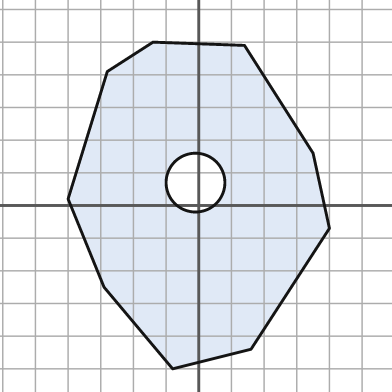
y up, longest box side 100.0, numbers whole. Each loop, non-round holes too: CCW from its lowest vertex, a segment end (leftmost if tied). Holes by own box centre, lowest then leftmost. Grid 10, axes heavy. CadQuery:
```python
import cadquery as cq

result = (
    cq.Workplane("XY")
    .moveTo(-8.0, -50.0)
    .lineTo(16.0, -44.0)
    .lineTo(40.0, -7.0)
    .lineTo(35.0, 16.0)
    .lineTo(14.0, 49.0)
    .lineTo(-14.0, 50.0)
    .lineTo(-28.0, 41.0)
    .lineTo(-40.0, 2.0)
    .lineTo(-29.0, -25.0)
    .close()
    .moveTo(-1.0, 7.0)
    .circle(9.0)
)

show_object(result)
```